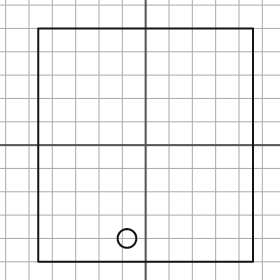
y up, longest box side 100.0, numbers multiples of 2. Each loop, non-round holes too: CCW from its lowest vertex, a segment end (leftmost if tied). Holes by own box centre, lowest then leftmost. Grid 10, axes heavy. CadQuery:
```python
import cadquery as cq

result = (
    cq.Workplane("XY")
    .moveTo(-46.0, -50.0)
    .lineTo(46.0, -50.0)
    .lineTo(46.0, 50.0)
    .lineTo(-46.0, 50.0)
    .close()
    .moveTo(-8.0, -40.0)
    .circle(4.0)
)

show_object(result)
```